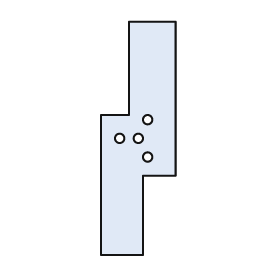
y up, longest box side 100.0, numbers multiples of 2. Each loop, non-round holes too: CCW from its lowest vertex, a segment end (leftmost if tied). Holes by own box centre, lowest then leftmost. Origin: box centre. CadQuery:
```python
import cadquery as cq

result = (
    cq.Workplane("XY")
    .moveTo(-16.0, -50.0)
    .lineTo(2.0, -50.0)
    .lineTo(2.0, -16.0)
    .lineTo(16.0, -16.0)
    .lineTo(16.0, 50.0)
    .lineTo(-4.0, 50.0)
    .lineTo(-4.0, 10.0)
    .lineTo(-16.0, 10.0)
    .close()
    .moveTo(4.0, -8.0)
    .circle(2.0)
    .moveTo(-8.0, 0.0)
    .circle(2.0)
    .moveTo(0.0, 0.0)
    .circle(2.0)
    .moveTo(4.0, 8.0)
    .circle(2.0)
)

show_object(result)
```